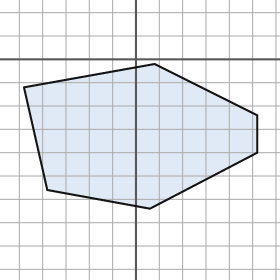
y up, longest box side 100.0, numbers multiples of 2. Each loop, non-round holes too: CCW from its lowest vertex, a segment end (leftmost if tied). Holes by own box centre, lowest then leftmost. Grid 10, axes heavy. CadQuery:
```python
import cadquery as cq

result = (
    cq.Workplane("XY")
    .moveTo(6.0, -64.0)
    .lineTo(52.0, -40.0)
    .lineTo(52.0, -24.0)
    .lineTo(8.0, -2.0)
    .lineTo(-48.0, -12.0)
    .lineTo(-38.0, -56.0)
    .close()
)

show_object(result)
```